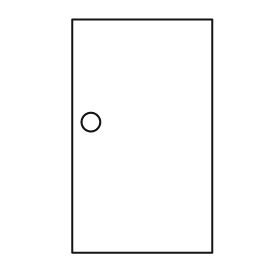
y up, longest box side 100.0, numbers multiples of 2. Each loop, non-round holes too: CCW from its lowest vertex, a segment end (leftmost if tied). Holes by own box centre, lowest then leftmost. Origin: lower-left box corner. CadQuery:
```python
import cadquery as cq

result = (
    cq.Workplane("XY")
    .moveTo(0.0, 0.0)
    .lineTo(60.0, 0.0)
    .lineTo(60.0, 100.0)
    .lineTo(0.0, 100.0)
    .close()
    .moveTo(8.0, 56.0)
    .circle(4.0)
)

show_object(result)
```